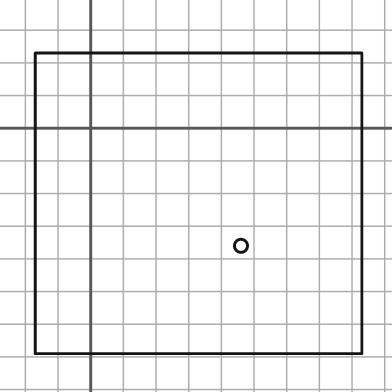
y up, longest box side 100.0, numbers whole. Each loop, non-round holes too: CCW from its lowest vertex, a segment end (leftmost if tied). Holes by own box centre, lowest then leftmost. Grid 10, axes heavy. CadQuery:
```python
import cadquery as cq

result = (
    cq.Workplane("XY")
    .moveTo(-17.0, -69.0)
    .lineTo(83.0, -69.0)
    .lineTo(83.0, 23.0)
    .lineTo(-17.0, 23.0)
    .close()
    .moveTo(46.0, -36.0)
    .circle(2.0)
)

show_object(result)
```